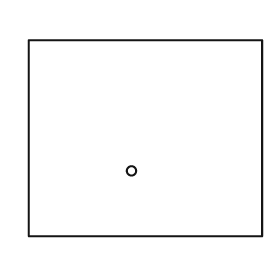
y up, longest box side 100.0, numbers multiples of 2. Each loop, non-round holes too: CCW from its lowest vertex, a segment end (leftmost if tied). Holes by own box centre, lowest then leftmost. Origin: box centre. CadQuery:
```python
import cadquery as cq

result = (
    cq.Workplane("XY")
    .moveTo(-50.0, -42.0)
    .lineTo(50.0, -42.0)
    .lineTo(50.0, 42.0)
    .lineTo(-50.0, 42.0)
    .close()
    .moveTo(-6.0, -14.0)
    .circle(2.0)
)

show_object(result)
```